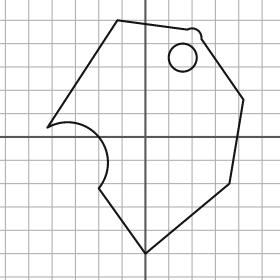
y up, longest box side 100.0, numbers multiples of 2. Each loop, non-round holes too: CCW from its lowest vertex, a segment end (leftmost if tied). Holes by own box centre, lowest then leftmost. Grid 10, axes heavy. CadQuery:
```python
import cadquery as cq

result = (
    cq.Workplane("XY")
    .moveTo(0.0, -50.0)
    .lineTo(36.0, -20.0)
    .lineTo(42.0, 16.0)
    .lineTo(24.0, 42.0)
    .threePointArc((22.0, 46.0), (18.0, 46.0))
    .lineTo(-12.0, 50.0)
    .lineTo(-42.0, 4.0)
    .threePointArc((-20.0, 0.0), (-20.0, -22.0))
    .close()
    .moveTo(16.0, 34.0)
    .circle(6.0)
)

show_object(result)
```